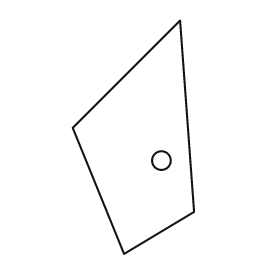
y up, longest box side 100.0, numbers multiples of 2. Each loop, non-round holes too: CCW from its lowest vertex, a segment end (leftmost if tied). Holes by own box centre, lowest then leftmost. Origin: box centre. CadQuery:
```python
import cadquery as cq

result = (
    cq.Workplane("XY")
    .moveTo(-4.0, -50.0)
    .lineTo(26.0, -32.0)
    .lineTo(20.0, 50.0)
    .lineTo(-26.0, 4.0)
    .close()
    .moveTo(12.0, -10.0)
    .circle(4.0)
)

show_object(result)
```